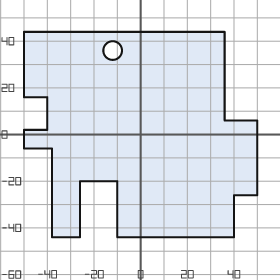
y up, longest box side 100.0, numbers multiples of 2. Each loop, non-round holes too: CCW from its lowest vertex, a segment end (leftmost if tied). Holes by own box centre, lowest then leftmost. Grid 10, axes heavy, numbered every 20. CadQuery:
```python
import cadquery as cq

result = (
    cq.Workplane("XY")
    .moveTo(-38.0, -44.0)
    .lineTo(-26.0, -44.0)
    .lineTo(-26.0, -20.0)
    .lineTo(-10.0, -20.0)
    .lineTo(-10.0, -44.0)
    .lineTo(40.0, -44.0)
    .lineTo(40.0, -26.0)
    .lineTo(50.0, -26.0)
    .lineTo(50.0, 6.0)
    .lineTo(36.0, 6.0)
    .lineTo(36.0, 44.0)
    .lineTo(-50.0, 44.0)
    .lineTo(-50.0, 16.0)
    .lineTo(-40.0, 16.0)
    .lineTo(-40.0, 2.0)
    .lineTo(-50.0, 2.0)
    .lineTo(-50.0, -6.0)
    .lineTo(-38.0, -6.0)
    .close()
    .moveTo(-12.0, 36.0)
    .circle(4.0)
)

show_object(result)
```